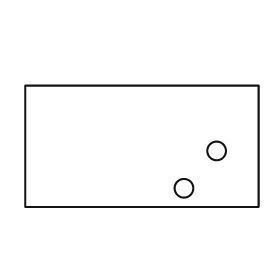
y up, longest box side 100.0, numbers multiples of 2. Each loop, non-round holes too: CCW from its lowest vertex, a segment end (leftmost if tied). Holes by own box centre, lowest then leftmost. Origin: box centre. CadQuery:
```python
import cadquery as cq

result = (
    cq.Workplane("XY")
    .moveTo(-50.0, -26.0)
    .lineTo(50.0, -26.0)
    .lineTo(50.0, 26.0)
    .lineTo(-50.0, 26.0)
    .close()
    .moveTo(18.0, -18.0)
    .circle(4.0)
    .moveTo(32.0, -2.0)
    .circle(4.0)
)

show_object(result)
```